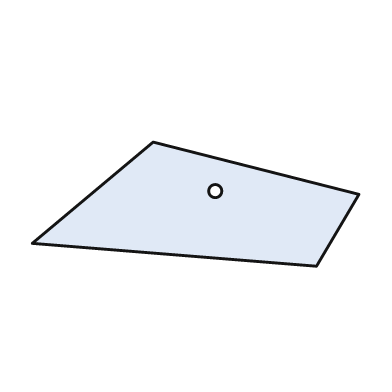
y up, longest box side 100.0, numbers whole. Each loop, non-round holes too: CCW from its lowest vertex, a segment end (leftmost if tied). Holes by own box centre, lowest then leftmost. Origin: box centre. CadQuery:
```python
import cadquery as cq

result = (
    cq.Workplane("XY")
    .moveTo(37.0, -19.0)
    .lineTo(50.0, 3.0)
    .lineTo(-13.0, 19.0)
    .lineTo(-50.0, -12.0)
    .close()
    .moveTo(6.0, 4.0)
    .circle(2.0)
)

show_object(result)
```